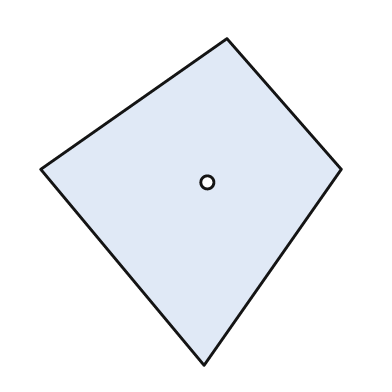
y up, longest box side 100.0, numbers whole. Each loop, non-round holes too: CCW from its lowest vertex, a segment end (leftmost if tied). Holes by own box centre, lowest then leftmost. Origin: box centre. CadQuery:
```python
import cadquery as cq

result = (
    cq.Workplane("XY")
    .moveTo(4.0, -50.0)
    .lineTo(46.0, 10.0)
    .lineTo(11.0, 50.0)
    .lineTo(-46.0, 10.0)
    .close()
    .moveTo(5.0, 6.0)
    .circle(2.0)
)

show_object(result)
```